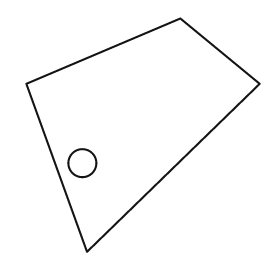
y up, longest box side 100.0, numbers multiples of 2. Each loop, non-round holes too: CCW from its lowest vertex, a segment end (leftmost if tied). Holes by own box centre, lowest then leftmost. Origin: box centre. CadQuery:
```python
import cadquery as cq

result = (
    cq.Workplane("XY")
    .moveTo(-24.0, -50.0)
    .lineTo(50.0, 22.0)
    .lineTo(16.0, 50.0)
    .lineTo(-50.0, 22.0)
    .close()
    .moveTo(-26.0, -12.0)
    .circle(6.0)
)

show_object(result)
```